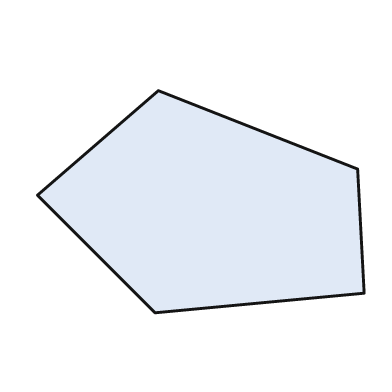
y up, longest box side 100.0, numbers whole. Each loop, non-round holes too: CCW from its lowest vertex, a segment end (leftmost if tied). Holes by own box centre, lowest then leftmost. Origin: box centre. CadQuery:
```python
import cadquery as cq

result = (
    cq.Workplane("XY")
    .moveTo(-14.0, -34.0)
    .lineTo(50.0, -28.0)
    .lineTo(48.0, 10.0)
    .lineTo(-13.0, 34.0)
    .lineTo(-50.0, 2.0)
    .close()
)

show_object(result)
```